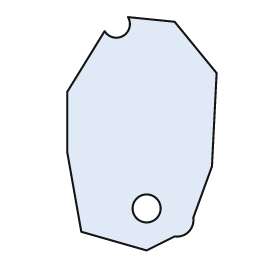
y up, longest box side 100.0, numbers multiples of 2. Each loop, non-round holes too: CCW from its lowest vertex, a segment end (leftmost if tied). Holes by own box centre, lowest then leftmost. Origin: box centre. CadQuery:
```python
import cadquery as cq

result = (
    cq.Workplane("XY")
    .moveTo(2.0, -50.0)
    .lineTo(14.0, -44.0)
    .threePointArc((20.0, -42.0), (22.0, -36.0))
    .lineTo(30.0, -14.0)
    .lineTo(32.0, 26.0)
    .lineTo(14.0, 48.0)
    .lineTo(-6.0, 50.0)
    .threePointArc((-8.0, 42.0), (-16.0, 44.0))
    .lineTo(-32.0, 18.0)
    .lineTo(-32.0, -8.0)
    .lineTo(-26.0, -42.0)
    .close()
    .moveTo(2.0, -32.0)
    .circle(6.0)
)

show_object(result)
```